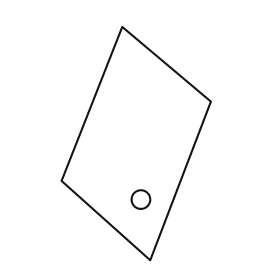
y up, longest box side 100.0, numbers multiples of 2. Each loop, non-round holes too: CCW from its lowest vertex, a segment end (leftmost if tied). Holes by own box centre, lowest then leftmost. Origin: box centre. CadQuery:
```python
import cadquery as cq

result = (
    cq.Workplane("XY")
    .moveTo(6.0, -50.0)
    .lineTo(32.0, 18.0)
    .lineTo(-6.0, 50.0)
    .lineTo(-32.0, -16.0)
    .close()
    .moveTo(2.0, -24.0)
    .circle(4.0)
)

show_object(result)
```